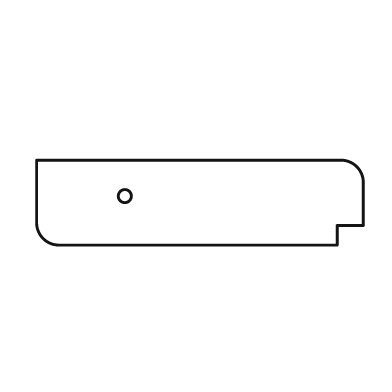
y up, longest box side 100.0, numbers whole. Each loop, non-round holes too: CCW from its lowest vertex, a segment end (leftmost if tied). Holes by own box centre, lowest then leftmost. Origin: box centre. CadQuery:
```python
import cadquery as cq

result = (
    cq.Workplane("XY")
    .moveTo(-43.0, -13.0)
    .lineTo(42.0, -13.0)
    .lineTo(42.0, -7.0)
    .lineTo(50.0, -7.0)
    .lineTo(50.0, 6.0)
    .threePointArc((48.0, 11.0), (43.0, 13.0))
    .lineTo(-50.0, 13.0)
    .lineTo(-50.0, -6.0)
    .threePointArc((-48.0, -11.0), (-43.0, -13.0))
    .close()
    .moveTo(-23.0, 2.0)
    .circle(2.0)
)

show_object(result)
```